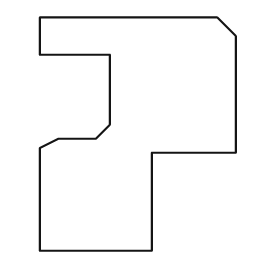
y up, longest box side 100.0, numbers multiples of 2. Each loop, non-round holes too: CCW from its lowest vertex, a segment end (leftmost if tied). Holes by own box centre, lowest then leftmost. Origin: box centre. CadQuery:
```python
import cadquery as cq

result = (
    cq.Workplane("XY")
    .moveTo(-42.0, -50.0)
    .lineTo(6.0, -50.0)
    .lineTo(6.0, -8.0)
    .lineTo(42.0, -8.0)
    .lineTo(42.0, 42.0)
    .lineTo(34.0, 50.0)
    .lineTo(-42.0, 50.0)
    .lineTo(-42.0, 34.0)
    .lineTo(-12.0, 34.0)
    .lineTo(-12.0, 4.0)
    .lineTo(-18.0, -2.0)
    .lineTo(-34.0, -2.0)
    .lineTo(-42.0, -6.0)
    .close()
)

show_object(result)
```